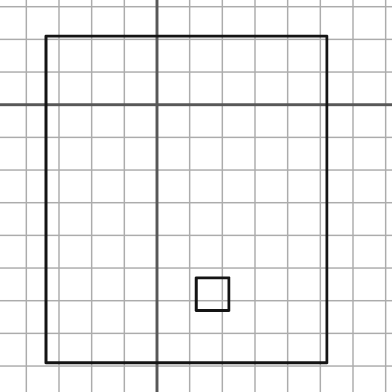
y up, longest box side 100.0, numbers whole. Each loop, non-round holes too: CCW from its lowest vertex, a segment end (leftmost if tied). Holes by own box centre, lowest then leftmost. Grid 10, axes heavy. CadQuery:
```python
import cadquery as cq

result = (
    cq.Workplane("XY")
    .moveTo(-34.0, -79.0)
    .lineTo(52.0, -79.0)
    .lineTo(52.0, 21.0)
    .lineTo(-34.0, 21.0)
    .close()
    .moveTo(12.0, -63.0)
    .lineTo(22.0, -63.0)
    .lineTo(22.0, -53.0)
    .lineTo(12.0, -53.0)
    .close()
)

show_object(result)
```